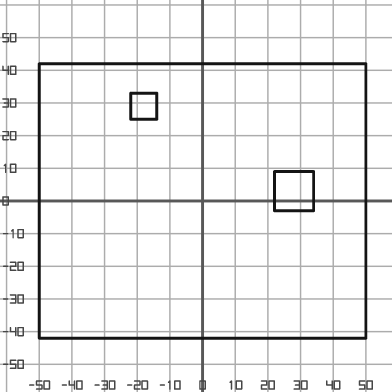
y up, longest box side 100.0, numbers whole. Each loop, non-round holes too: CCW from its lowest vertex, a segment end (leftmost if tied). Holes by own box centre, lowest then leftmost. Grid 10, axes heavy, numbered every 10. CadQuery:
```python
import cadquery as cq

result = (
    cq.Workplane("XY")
    .moveTo(-50.0, -42.0)
    .lineTo(50.0, -42.0)
    .lineTo(50.0, 42.0)
    .lineTo(-50.0, 42.0)
    .close()
    .moveTo(22.0, -3.0)
    .lineTo(34.0, -3.0)
    .lineTo(34.0, 9.0)
    .lineTo(22.0, 9.0)
    .close()
    .moveTo(-22.0, 25.0)
    .lineTo(-14.0, 25.0)
    .lineTo(-14.0, 33.0)
    .lineTo(-22.0, 33.0)
    .close()
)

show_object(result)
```